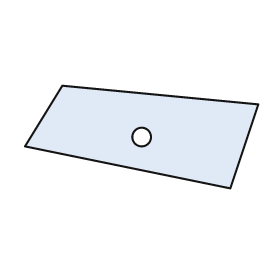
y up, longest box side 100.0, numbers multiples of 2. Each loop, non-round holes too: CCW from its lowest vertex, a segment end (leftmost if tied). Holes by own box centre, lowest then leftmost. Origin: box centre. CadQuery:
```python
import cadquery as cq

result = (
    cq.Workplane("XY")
    .moveTo(38.0, -22.0)
    .lineTo(50.0, 14.0)
    .lineTo(-34.0, 22.0)
    .lineTo(-50.0, -4.0)
    .close()
    .moveTo(0.0, 0.0)
    .circle(4.0)
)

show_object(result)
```